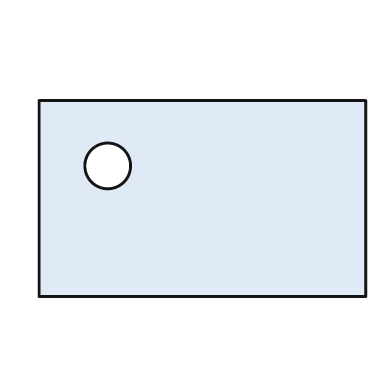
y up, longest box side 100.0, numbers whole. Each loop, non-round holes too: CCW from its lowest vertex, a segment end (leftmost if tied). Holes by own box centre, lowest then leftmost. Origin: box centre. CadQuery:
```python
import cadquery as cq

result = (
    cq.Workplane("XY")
    .moveTo(-50.0, -30.0)
    .lineTo(50.0, -30.0)
    .lineTo(50.0, 30.0)
    .lineTo(-50.0, 30.0)
    .close()
    .moveTo(-29.0, 10.0)
    .circle(7.0)
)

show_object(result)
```